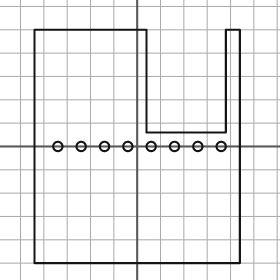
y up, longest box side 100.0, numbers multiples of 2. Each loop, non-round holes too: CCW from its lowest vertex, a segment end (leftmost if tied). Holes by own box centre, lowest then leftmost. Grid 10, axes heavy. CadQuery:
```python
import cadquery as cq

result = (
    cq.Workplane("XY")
    .moveTo(-44.0, -50.0)
    .lineTo(44.0, -50.0)
    .lineTo(44.0, 50.0)
    .lineTo(38.0, 50.0)
    .lineTo(38.0, 6.0)
    .lineTo(4.0, 6.0)
    .lineTo(4.0, 50.0)
    .lineTo(-44.0, 50.0)
    .close()
    .moveTo(-34.0, 0.0)
    .circle(2.0)
    .moveTo(-24.0, 0.0)
    .circle(2.0)
    .moveTo(-14.0, 0.0)
    .circle(2.0)
    .moveTo(-4.0, 0.0)
    .circle(2.0)
    .moveTo(6.0, 0.0)
    .circle(2.0)
    .moveTo(16.0, 0.0)
    .circle(2.0)
    .moveTo(26.0, 0.0)
    .circle(2.0)
    .moveTo(36.0, 0.0)
    .circle(2.0)
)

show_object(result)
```